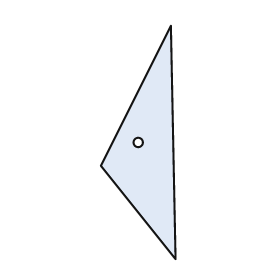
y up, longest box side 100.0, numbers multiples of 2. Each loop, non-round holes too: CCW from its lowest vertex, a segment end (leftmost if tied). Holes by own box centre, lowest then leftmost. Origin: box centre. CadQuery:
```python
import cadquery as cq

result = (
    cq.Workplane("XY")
    .moveTo(16.0, -50.0)
    .lineTo(14.0, 50.0)
    .lineTo(-16.0, -10.0)
    .close()
    .moveTo(0.0, 0.0)
    .circle(2.0)
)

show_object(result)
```